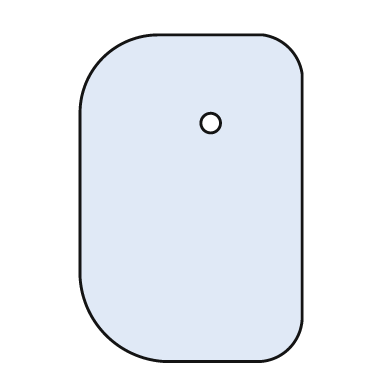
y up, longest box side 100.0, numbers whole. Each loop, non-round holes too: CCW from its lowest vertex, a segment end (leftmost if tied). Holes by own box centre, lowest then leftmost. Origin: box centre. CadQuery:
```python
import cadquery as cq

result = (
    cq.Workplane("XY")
    .moveTo(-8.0, -50.0)
    .lineTo(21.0, -50.0)
    .threePointArc((30.0, -46.0), (34.0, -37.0))
    .lineTo(34.0, 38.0)
    .threePointArc((30.0, 46.0), (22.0, 50.0))
    .lineTo(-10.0, 50.0)
    .threePointArc((-27.0, 43.0), (-34.0, 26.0))
    .lineTo(-34.0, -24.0)
    .threePointArc((-26.0, -42.0), (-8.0, -50.0))
    .close()
    .moveTo(6.0, 23.0)
    .circle(3.0)
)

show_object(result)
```